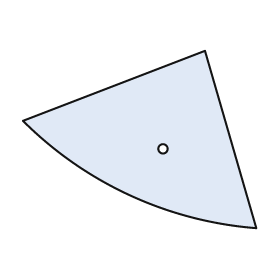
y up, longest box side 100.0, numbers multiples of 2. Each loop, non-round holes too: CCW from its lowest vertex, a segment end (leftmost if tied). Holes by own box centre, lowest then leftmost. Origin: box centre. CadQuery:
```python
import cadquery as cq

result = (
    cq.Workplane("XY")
    .moveTo(50.0, -38.0)
    .lineTo(28.0, 38.0)
    .lineTo(-50.0, 8.0)
    .threePointArc((-4.0, -24.0), (50.0, -38.0))
    .close()
    .moveTo(10.0, -4.0)
    .circle(2.0)
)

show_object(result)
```